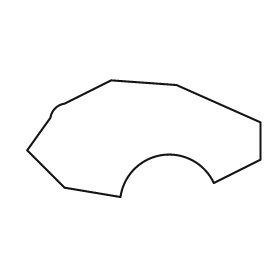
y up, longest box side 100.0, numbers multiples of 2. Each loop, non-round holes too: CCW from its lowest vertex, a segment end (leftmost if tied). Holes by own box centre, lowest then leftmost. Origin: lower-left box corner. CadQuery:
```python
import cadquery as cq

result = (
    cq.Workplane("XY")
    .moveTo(40.0, 0.0)
    .threePointArc((58.0, 18.0), (80.0, 6.0))
    .lineTo(100.0, 16.0)
    .lineTo(100.0, 32.0)
    .lineTo(64.0, 48.0)
    .lineTo(36.0, 50.0)
    .lineTo(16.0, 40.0)
    .threePointArc((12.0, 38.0), (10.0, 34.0))
    .lineTo(0.0, 20.0)
    .lineTo(16.0, 4.0)
    .close()
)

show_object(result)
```